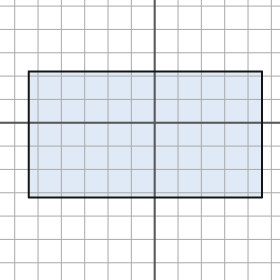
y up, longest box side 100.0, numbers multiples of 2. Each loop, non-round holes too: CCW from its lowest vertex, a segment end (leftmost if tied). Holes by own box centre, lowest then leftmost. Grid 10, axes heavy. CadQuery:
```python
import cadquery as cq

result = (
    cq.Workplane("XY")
    .moveTo(-54.0, -32.0)
    .lineTo(46.0, -32.0)
    .lineTo(46.0, 22.0)
    .lineTo(-54.0, 22.0)
    .close()
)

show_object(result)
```